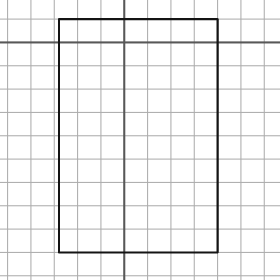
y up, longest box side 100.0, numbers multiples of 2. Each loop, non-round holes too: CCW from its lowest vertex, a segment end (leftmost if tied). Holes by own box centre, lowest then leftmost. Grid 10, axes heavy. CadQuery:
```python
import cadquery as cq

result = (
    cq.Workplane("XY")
    .moveTo(-28.0, -90.0)
    .lineTo(40.0, -90.0)
    .lineTo(40.0, 10.0)
    .lineTo(-28.0, 10.0)
    .close()
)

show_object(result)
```